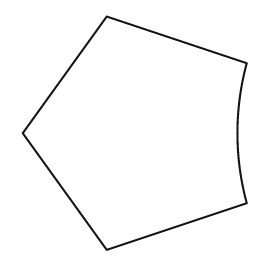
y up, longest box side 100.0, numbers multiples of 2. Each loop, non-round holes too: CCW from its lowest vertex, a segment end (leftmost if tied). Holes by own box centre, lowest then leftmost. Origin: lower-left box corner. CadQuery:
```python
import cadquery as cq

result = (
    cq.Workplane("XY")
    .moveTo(36.0, 0.0)
    .lineTo(96.0, 20.0)
    .threePointArc((92.0, 50.0), (96.0, 80.0))
    .lineTo(36.0, 100.0)
    .lineTo(0.0, 50.0)
    .close()
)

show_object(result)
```